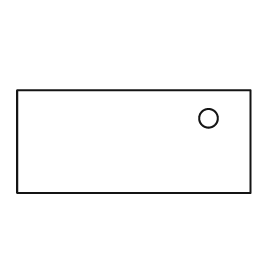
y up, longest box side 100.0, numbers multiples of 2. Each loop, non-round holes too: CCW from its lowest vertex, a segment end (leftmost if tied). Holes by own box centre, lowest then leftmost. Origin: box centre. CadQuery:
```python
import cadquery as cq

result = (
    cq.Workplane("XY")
    .moveTo(-50.0, -22.0)
    .lineTo(50.0, -22.0)
    .lineTo(50.0, 22.0)
    .lineTo(-50.0, 22.0)
    .close()
    .moveTo(32.0, 10.0)
    .circle(4.0)
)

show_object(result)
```